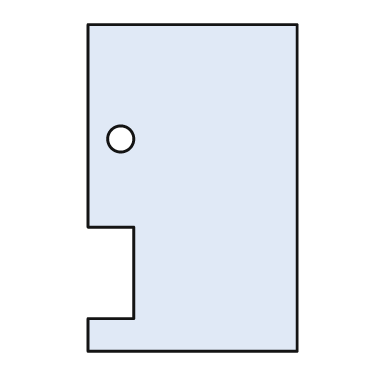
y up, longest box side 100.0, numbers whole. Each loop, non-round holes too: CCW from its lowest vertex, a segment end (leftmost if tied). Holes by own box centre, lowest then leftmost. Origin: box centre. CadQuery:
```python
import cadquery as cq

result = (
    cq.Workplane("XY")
    .moveTo(-32.0, -50.0)
    .lineTo(32.0, -50.0)
    .lineTo(32.0, 50.0)
    .lineTo(-32.0, 50.0)
    .lineTo(-32.0, -12.0)
    .lineTo(-18.0, -12.0)
    .lineTo(-18.0, -40.0)
    .lineTo(-32.0, -40.0)
    .close()
    .moveTo(-22.0, 15.0)
    .circle(4.0)
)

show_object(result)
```